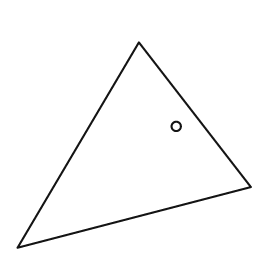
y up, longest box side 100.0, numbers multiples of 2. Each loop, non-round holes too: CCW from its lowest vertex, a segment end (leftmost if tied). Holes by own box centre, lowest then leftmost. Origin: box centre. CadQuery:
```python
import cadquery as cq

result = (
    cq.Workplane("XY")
    .moveTo(-50.0, -44.0)
    .lineTo(50.0, -18.0)
    .lineTo(2.0, 44.0)
    .close()
    .moveTo(18.0, 8.0)
    .circle(2.0)
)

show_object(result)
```